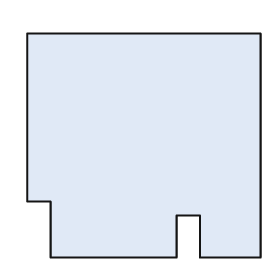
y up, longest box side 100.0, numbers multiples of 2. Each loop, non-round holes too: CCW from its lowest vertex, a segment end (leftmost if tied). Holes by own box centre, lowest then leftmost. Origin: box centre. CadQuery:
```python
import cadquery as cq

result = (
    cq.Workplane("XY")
    .moveTo(-40.0, -48.0)
    .lineTo(14.0, -48.0)
    .lineTo(14.0, -30.0)
    .lineTo(24.0, -30.0)
    .lineTo(24.0, -48.0)
    .lineTo(50.0, -48.0)
    .lineTo(50.0, 48.0)
    .lineTo(-50.0, 48.0)
    .lineTo(-50.0, -24.0)
    .lineTo(-40.0, -24.0)
    .close()
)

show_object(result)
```